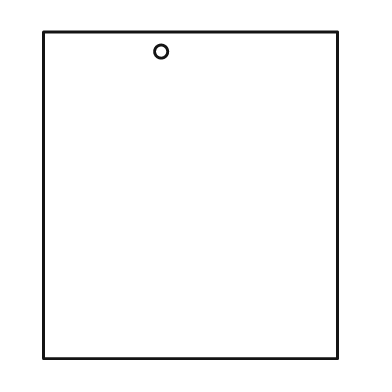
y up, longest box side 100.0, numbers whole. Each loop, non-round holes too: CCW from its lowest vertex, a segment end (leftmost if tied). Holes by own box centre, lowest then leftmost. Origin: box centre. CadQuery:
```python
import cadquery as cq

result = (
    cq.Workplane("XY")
    .moveTo(-45.0, -50.0)
    .lineTo(45.0, -50.0)
    .lineTo(45.0, 50.0)
    .lineTo(-45.0, 50.0)
    .close()
    .moveTo(-9.0, 44.0)
    .circle(2.0)
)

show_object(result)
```